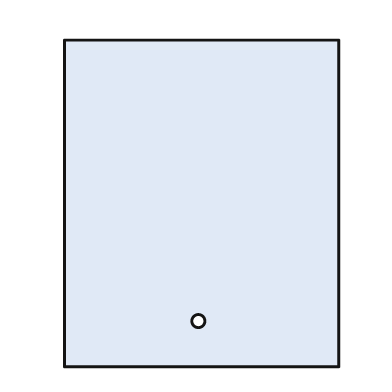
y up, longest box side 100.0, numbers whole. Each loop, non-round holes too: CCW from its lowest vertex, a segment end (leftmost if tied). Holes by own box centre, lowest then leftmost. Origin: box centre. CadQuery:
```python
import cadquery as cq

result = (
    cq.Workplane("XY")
    .moveTo(-42.0, -50.0)
    .lineTo(42.0, -50.0)
    .lineTo(42.0, 50.0)
    .lineTo(-42.0, 50.0)
    .close()
    .moveTo(-1.0, -36.0)
    .circle(2.0)
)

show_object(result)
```